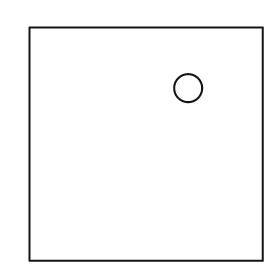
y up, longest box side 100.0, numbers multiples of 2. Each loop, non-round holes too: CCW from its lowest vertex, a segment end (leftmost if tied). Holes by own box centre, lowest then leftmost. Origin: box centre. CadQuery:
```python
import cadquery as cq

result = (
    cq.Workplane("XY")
    .moveTo(-50.0, -50.0)
    .lineTo(50.0, -50.0)
    .lineTo(50.0, 50.0)
    .lineTo(-50.0, 50.0)
    .close()
    .moveTo(18.0, 24.0)
    .circle(6.0)
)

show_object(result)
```